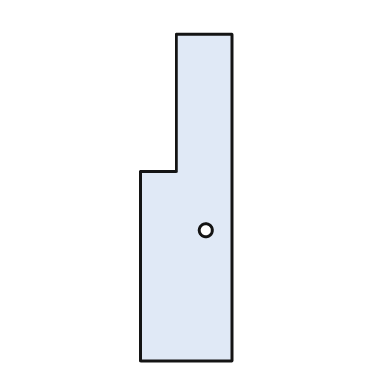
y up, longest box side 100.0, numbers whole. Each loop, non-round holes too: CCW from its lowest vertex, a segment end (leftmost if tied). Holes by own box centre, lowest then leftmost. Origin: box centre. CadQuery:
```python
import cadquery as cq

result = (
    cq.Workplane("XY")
    .moveTo(-14.0, -50.0)
    .lineTo(14.0, -50.0)
    .lineTo(14.0, 50.0)
    .lineTo(-3.0, 50.0)
    .lineTo(-3.0, 8.0)
    .lineTo(-14.0, 8.0)
    .close()
    .moveTo(6.0, -10.0)
    .circle(2.0)
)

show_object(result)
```